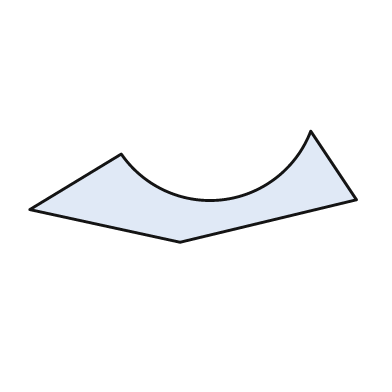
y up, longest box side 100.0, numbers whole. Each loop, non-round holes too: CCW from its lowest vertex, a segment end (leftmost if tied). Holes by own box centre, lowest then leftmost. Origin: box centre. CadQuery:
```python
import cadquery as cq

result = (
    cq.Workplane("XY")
    .moveTo(-4.0, -17.0)
    .lineTo(50.0, -4.0)
    .lineTo(36.0, 17.0)
    .threePointArc((9.0, -4.0), (-22.0, 10.0))
    .lineTo(-50.0, -7.0)
    .close()
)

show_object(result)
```